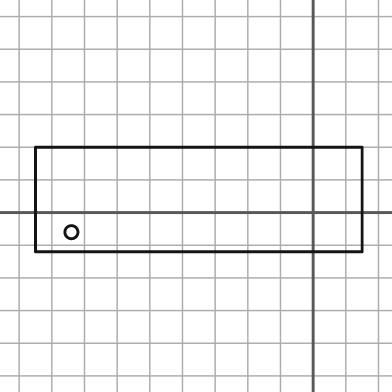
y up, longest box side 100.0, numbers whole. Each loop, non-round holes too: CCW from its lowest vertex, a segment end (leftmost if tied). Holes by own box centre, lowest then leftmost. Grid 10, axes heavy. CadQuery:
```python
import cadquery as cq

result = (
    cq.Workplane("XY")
    .moveTo(-85.0, -12.0)
    .lineTo(15.0, -12.0)
    .lineTo(15.0, 20.0)
    .lineTo(-85.0, 20.0)
    .close()
    .moveTo(-74.0, -6.0)
    .circle(2.0)
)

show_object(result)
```